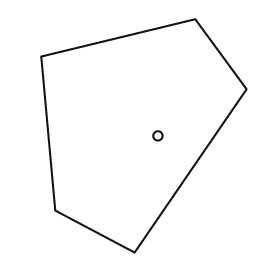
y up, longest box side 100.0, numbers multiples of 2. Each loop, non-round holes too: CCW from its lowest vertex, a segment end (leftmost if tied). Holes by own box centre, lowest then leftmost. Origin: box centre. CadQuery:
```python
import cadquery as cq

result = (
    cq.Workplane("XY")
    .moveTo(-4.0, -50.0)
    .lineTo(44.0, 20.0)
    .lineTo(22.0, 50.0)
    .lineTo(-44.0, 34.0)
    .lineTo(-38.0, -32.0)
    .close()
    .moveTo(6.0, 0.0)
    .circle(2.0)
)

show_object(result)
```